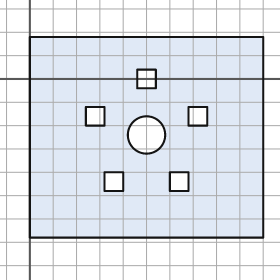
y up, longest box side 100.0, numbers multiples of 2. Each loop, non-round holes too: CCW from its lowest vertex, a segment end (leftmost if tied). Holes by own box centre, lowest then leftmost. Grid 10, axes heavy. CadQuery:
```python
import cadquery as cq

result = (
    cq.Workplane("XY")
    .moveTo(0.0, -68.0)
    .lineTo(100.0, -68.0)
    .lineTo(100.0, 18.0)
    .lineTo(0.0, 18.0)
    .close()
    .moveTo(32.0, -48.0)
    .lineTo(40.0, -48.0)
    .lineTo(40.0, -40.0)
    .lineTo(32.0, -40.0)
    .close()
    .moveTo(60.0, -48.0)
    .lineTo(68.0, -48.0)
    .lineTo(68.0, -40.0)
    .lineTo(60.0, -40.0)
    .close()
    .moveTo(50.0, -24.0)
    .circle(8.0)
    .moveTo(24.0, -20.0)
    .lineTo(32.0, -20.0)
    .lineTo(32.0, -12.0)
    .lineTo(24.0, -12.0)
    .close()
    .moveTo(68.0, -20.0)
    .lineTo(76.0, -20.0)
    .lineTo(76.0, -12.0)
    .lineTo(68.0, -12.0)
    .close()
    .moveTo(46.0, -4.0)
    .lineTo(54.0, -4.0)
    .lineTo(54.0, 4.0)
    .lineTo(46.0, 4.0)
    .close()
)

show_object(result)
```